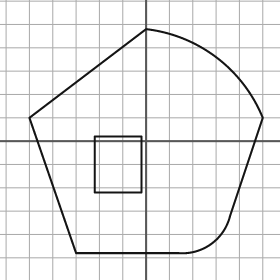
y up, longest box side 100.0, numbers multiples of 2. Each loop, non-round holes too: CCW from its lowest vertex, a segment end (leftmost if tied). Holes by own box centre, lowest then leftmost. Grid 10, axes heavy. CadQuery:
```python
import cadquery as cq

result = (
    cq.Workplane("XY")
    .moveTo(-30.0, -48.0)
    .lineTo(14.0, -48.0)
    .threePointArc((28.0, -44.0), (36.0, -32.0))
    .lineTo(50.0, 10.0)
    .threePointArc((30.0, 36.0), (0.0, 48.0))
    .lineTo(-50.0, 10.0)
    .close()
    .moveTo(-22.0, -22.0)
    .lineTo(-2.0, -22.0)
    .lineTo(-2.0, 2.0)
    .lineTo(-22.0, 2.0)
    .close()
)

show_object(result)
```